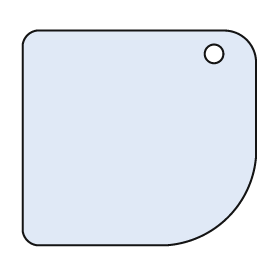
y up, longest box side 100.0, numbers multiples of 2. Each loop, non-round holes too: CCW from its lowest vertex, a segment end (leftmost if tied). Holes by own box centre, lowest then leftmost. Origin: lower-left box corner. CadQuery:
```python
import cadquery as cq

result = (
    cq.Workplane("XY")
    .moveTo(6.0, 0.0)
    .lineTo(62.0, 0.0)
    .threePointArc((88.0, 12.0), (100.0, 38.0))
    .lineTo(100.0, 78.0)
    .threePointArc((96.0, 88.0), (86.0, 92.0))
    .lineTo(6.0, 92.0)
    .threePointArc((2.0, 90.0), (0.0, 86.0))
    .lineTo(0.0, 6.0)
    .threePointArc((2.0, 2.0), (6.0, 0.0))
    .close()
    .moveTo(82.0, 82.0)
    .circle(4.0)
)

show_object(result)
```